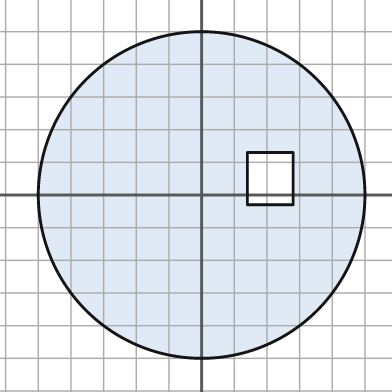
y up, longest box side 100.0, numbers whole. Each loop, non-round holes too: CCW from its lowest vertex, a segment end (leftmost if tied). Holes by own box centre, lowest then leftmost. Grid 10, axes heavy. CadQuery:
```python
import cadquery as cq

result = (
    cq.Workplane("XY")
    .moveTo(0.0, 0.0)
    .circle(50.0)
    .moveTo(14.0, -3.0)
    .lineTo(28.0, -3.0)
    .lineTo(28.0, 13.0)
    .lineTo(14.0, 13.0)
    .close()
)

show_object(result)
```